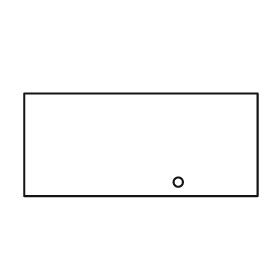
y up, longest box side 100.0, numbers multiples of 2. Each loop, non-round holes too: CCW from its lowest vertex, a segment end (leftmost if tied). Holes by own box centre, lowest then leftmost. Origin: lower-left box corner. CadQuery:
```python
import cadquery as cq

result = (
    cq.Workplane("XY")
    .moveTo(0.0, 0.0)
    .lineTo(100.0, 0.0)
    .lineTo(100.0, 44.0)
    .lineTo(0.0, 44.0)
    .close()
    .moveTo(66.0, 6.0)
    .circle(2.0)
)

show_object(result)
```